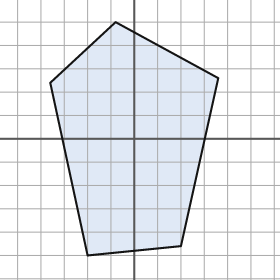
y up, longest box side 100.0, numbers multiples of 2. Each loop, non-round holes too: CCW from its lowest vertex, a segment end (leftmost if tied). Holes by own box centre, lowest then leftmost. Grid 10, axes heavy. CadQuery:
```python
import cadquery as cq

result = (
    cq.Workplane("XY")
    .moveTo(-20.0, -50.0)
    .lineTo(20.0, -46.0)
    .lineTo(36.0, 26.0)
    .lineTo(-8.0, 50.0)
    .lineTo(-36.0, 24.0)
    .close()
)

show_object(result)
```